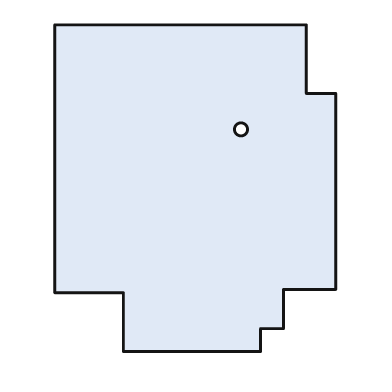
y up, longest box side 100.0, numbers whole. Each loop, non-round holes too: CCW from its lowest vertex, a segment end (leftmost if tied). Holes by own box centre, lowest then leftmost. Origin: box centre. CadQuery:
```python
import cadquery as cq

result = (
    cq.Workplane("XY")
    .moveTo(-22.0, -50.0)
    .lineTo(20.0, -50.0)
    .lineTo(20.0, -43.0)
    .lineTo(27.0, -43.0)
    .lineTo(27.0, -31.0)
    .lineTo(43.0, -31.0)
    .lineTo(43.0, 29.0)
    .lineTo(34.0, 29.0)
    .lineTo(34.0, 50.0)
    .lineTo(-43.0, 50.0)
    .lineTo(-43.0, -32.0)
    .lineTo(-22.0, -32.0)
    .close()
    .moveTo(14.0, 18.0)
    .circle(2.0)
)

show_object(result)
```